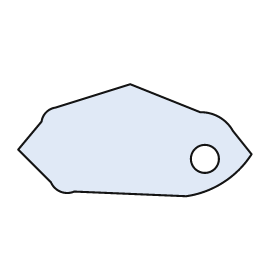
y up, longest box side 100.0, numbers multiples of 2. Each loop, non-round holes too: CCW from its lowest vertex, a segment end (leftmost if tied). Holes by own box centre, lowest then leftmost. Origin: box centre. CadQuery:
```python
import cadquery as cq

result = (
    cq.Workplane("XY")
    .moveTo(22.0, -24.0)
    .threePointArc((38.0, -18.0), (50.0, -6.0))
    .lineTo(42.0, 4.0)
    .threePointArc((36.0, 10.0), (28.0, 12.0))
    .lineTo(-2.0, 24.0)
    .lineTo(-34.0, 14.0)
    .threePointArc((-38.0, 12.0), (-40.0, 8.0))
    .lineTo(-50.0, -4.0)
    .lineTo(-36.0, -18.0)
    .threePointArc((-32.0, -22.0), (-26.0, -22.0))
    .close()
    .moveTo(30.0, -8.0)
    .circle(6.0)
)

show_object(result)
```